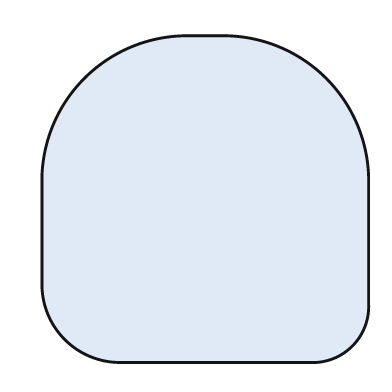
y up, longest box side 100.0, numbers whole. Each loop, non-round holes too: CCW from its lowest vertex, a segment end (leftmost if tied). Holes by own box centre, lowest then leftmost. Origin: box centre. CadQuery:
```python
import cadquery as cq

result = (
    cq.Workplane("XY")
    .moveTo(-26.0, -50.0)
    .lineTo(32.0, -50.0)
    .threePointArc((45.0, -45.0), (50.0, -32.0))
    .lineTo(50.0, 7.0)
    .threePointArc((37.0, 37.0), (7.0, 50.0))
    .lineTo(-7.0, 50.0)
    .threePointArc((-37.0, 37.0), (-50.0, 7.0))
    .lineTo(-50.0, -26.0)
    .threePointArc((-43.0, -43.0), (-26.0, -50.0))
    .close()
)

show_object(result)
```